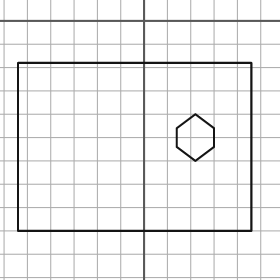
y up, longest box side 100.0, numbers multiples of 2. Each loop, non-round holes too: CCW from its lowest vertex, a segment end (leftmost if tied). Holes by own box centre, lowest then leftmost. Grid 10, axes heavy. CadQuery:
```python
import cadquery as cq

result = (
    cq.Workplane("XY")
    .moveTo(-54.0, -90.0)
    .lineTo(46.0, -90.0)
    .lineTo(46.0, -18.0)
    .lineTo(-54.0, -18.0)
    .close()
    .moveTo(22.0, -60.0)
    .lineTo(30.0, -54.0)
    .lineTo(30.0, -46.0)
    .lineTo(22.0, -40.0)
    .lineTo(14.0, -46.0)
    .lineTo(14.0, -54.0)
    .close()
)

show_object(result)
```